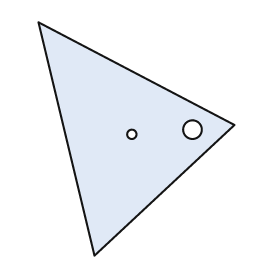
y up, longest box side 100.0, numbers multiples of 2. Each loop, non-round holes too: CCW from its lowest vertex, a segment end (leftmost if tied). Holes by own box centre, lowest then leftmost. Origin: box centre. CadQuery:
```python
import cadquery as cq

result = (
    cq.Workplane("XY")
    .moveTo(-18.0, -50.0)
    .lineTo(42.0, 6.0)
    .lineTo(-42.0, 50.0)
    .close()
    .moveTo(-2.0, 2.0)
    .circle(2.0)
    .moveTo(24.0, 4.0)
    .circle(4.0)
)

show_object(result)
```